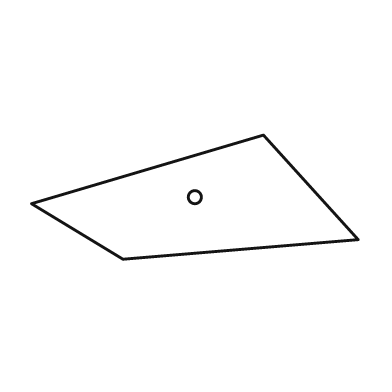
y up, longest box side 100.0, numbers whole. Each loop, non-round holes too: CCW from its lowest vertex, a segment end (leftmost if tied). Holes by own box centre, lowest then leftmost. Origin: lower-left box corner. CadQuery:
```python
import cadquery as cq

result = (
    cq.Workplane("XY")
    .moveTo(28.0, 0.0)
    .lineTo(100.0, 6.0)
    .lineTo(71.0, 38.0)
    .lineTo(0.0, 17.0)
    .close()
    .moveTo(50.0, 19.0)
    .circle(2.0)
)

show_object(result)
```